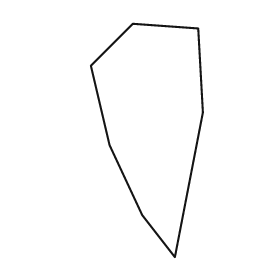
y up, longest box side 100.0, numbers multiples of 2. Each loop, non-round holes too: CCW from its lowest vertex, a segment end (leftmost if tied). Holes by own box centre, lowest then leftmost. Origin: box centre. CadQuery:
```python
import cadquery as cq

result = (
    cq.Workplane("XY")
    .moveTo(12.0, -50.0)
    .lineTo(24.0, 12.0)
    .lineTo(22.0, 48.0)
    .lineTo(-6.0, 50.0)
    .lineTo(-24.0, 32.0)
    .lineTo(-16.0, -2.0)
    .lineTo(-2.0, -32.0)
    .close()
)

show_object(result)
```